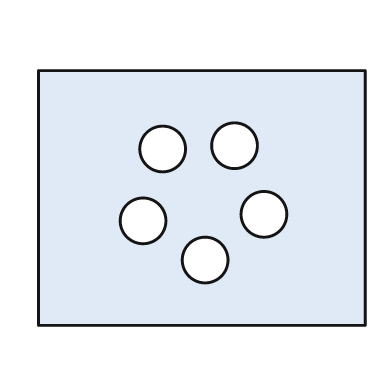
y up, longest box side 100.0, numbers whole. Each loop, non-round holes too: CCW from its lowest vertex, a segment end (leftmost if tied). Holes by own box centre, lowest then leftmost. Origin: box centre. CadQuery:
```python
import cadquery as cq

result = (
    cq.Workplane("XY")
    .moveTo(-50.0, -39.0)
    .lineTo(50.0, -39.0)
    .lineTo(50.0, 39.0)
    .lineTo(-50.0, 39.0)
    .close()
    .moveTo(1.0, -19.0)
    .circle(7.0)
    .moveTo(-18.0, -7.0)
    .circle(7.0)
    .moveTo(19.0, -5.0)
    .circle(7.0)
    .moveTo(-12.0, 15.0)
    .circle(7.0)
    .moveTo(10.0, 16.0)
    .circle(7.0)
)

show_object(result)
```